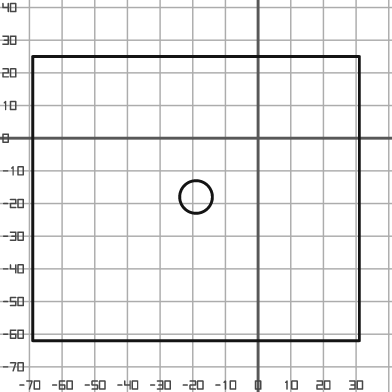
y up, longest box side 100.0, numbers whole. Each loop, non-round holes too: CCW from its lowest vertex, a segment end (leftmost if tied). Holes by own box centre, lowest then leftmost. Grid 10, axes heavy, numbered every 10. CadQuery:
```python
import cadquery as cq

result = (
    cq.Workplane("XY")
    .moveTo(-69.0, -62.0)
    .lineTo(31.0, -62.0)
    .lineTo(31.0, 25.0)
    .lineTo(-69.0, 25.0)
    .close()
    .moveTo(-19.0, -18.0)
    .circle(5.0)
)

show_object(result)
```